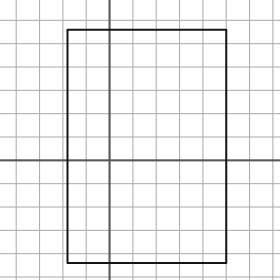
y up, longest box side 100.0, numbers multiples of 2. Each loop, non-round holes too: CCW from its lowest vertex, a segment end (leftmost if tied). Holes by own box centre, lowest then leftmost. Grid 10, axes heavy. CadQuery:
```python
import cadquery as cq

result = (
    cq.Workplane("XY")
    .moveTo(-18.0, -44.0)
    .lineTo(50.0, -44.0)
    .lineTo(50.0, 56.0)
    .lineTo(-18.0, 56.0)
    .close()
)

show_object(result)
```